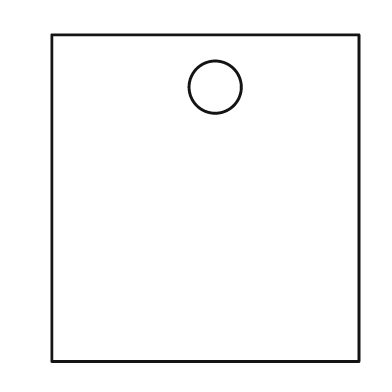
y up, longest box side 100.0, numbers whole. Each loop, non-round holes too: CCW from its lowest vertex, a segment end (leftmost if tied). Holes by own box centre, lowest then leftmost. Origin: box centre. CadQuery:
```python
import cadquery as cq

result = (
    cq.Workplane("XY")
    .moveTo(-47.0, -50.0)
    .lineTo(47.0, -50.0)
    .lineTo(47.0, 50.0)
    .lineTo(-47.0, 50.0)
    .close()
    .moveTo(3.0, 34.0)
    .circle(8.0)
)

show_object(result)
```